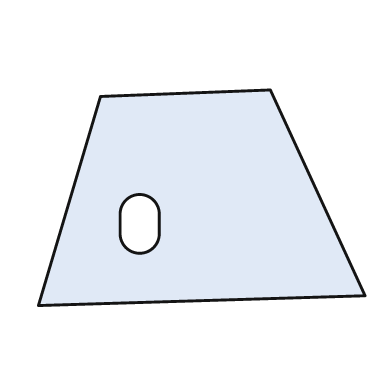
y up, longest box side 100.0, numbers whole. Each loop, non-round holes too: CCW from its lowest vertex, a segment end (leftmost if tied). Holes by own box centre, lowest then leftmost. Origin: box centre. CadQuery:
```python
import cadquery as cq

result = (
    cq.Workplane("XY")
    .moveTo(-50.0, -33.0)
    .lineTo(50.0, -30.0)
    .lineTo(21.0, 33.0)
    .lineTo(-31.0, 31.0)
    .close()
    .moveTo(-25.0, -11.0)
    .threePointArc((-19.0, -17.0), (-13.0, -11.0))
    .lineTo(-13.0, -5.0)
    .threePointArc((-19.0, 1.0), (-25.0, -5.0))
    .close()
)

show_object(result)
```